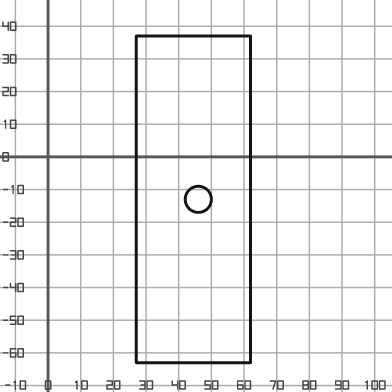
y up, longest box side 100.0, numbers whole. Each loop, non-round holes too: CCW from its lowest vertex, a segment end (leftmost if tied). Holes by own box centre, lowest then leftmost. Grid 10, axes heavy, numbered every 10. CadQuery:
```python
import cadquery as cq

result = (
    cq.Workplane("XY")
    .moveTo(27.0, -63.0)
    .lineTo(62.0, -63.0)
    .lineTo(62.0, 37.0)
    .lineTo(27.0, 37.0)
    .close()
    .moveTo(46.0, -13.0)
    .circle(4.0)
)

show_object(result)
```